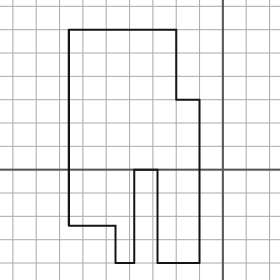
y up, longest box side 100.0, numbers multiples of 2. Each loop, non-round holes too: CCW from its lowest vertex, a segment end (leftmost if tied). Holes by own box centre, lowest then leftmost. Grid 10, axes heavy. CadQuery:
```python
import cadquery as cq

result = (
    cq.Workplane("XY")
    .moveTo(-46.0, -40.0)
    .lineTo(-38.0, -40.0)
    .lineTo(-38.0, 0.0)
    .lineTo(-28.0, 0.0)
    .lineTo(-28.0, -40.0)
    .lineTo(-10.0, -40.0)
    .lineTo(-10.0, 30.0)
    .lineTo(-20.0, 30.0)
    .lineTo(-20.0, 60.0)
    .lineTo(-66.0, 60.0)
    .lineTo(-66.0, -24.0)
    .lineTo(-46.0, -24.0)
    .close()
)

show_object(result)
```